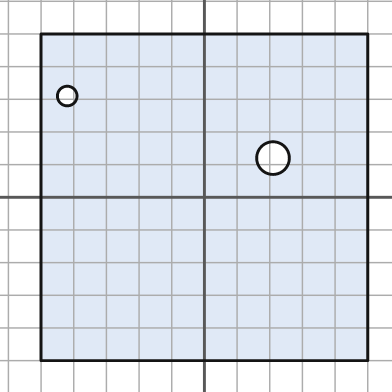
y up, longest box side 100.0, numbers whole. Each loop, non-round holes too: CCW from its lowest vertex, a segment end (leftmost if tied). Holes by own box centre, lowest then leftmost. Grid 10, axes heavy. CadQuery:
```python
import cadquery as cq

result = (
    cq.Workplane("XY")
    .moveTo(-50.0, -50.0)
    .lineTo(50.0, -50.0)
    .lineTo(50.0, 50.0)
    .lineTo(-50.0, 50.0)
    .close()
    .moveTo(21.0, 12.0)
    .circle(5.0)
    .moveTo(-42.0, 31.0)
    .circle(3.0)
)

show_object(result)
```